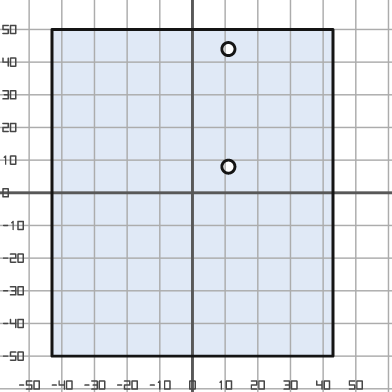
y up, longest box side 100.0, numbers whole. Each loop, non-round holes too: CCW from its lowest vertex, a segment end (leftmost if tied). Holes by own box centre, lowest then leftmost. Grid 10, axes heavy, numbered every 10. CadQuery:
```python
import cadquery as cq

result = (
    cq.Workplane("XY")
    .moveTo(-43.0, -50.0)
    .lineTo(43.0, -50.0)
    .lineTo(43.0, 50.0)
    .lineTo(-43.0, 50.0)
    .close()
    .moveTo(11.0, 8.0)
    .circle(2.0)
    .moveTo(11.0, 44.0)
    .circle(2.0)
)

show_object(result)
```